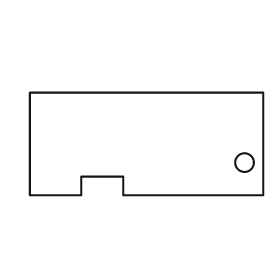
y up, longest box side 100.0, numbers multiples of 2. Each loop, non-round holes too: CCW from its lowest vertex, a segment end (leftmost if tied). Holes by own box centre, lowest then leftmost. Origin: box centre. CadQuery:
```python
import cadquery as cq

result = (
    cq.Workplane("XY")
    .moveTo(-50.0, -22.0)
    .lineTo(-28.0, -22.0)
    .lineTo(-28.0, -14.0)
    .lineTo(-10.0, -14.0)
    .lineTo(-10.0, -22.0)
    .lineTo(50.0, -22.0)
    .lineTo(50.0, 22.0)
    .lineTo(-50.0, 22.0)
    .close()
    .moveTo(42.0, -8.0)
    .circle(4.0)
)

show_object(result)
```